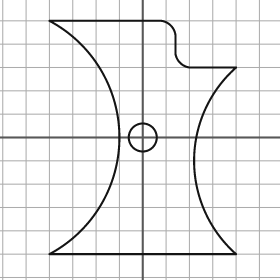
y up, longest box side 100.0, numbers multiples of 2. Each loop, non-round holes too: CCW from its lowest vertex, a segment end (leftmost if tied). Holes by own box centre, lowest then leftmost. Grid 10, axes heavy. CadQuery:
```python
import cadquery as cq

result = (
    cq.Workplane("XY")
    .moveTo(-40.0, -50.0)
    .lineTo(40.0, -50.0)
    .threePointArc((22.0, -10.0), (40.0, 30.0))
    .lineTo(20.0, 30.0)
    .threePointArc((16.0, 32.0), (14.0, 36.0))
    .lineTo(14.0, 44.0)
    .threePointArc((12.0, 48.0), (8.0, 50.0))
    .lineTo(-40.0, 50.0)
    .threePointArc((-10.0, 0.0), (-40.0, -50.0))
    .close()
    .moveTo(0.0, 0.0)
    .circle(6.0)
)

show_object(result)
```